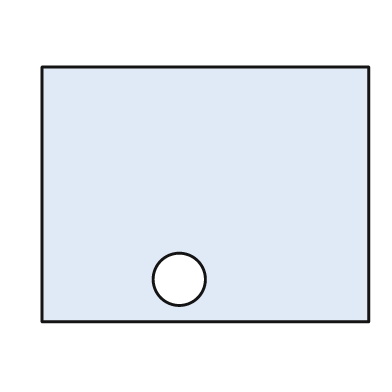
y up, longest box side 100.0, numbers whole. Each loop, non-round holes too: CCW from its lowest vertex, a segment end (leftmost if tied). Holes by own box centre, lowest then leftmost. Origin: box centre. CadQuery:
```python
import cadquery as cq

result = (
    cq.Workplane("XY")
    .moveTo(-50.0, -39.0)
    .lineTo(50.0, -39.0)
    .lineTo(50.0, 39.0)
    .lineTo(-50.0, 39.0)
    .close()
    .moveTo(-8.0, -26.0)
    .circle(8.0)
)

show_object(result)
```